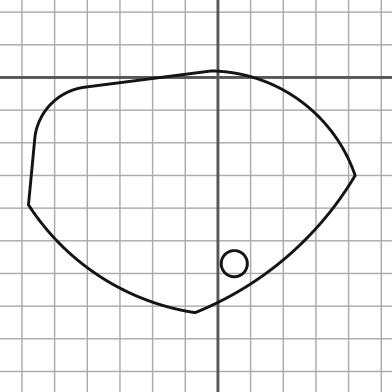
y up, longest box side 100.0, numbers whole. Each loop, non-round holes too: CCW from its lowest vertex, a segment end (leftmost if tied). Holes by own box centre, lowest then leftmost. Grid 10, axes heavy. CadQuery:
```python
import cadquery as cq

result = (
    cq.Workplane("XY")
    .moveTo(-7.0, -72.0)
    .threePointArc((21.0, -55.0), (42.0, -30.0))
    .threePointArc((25.0, -7.0), (-2.0, 2.0))
    .lineTo(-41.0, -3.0)
    .threePointArc((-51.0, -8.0), (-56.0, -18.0))
    .lineTo(-58.0, -39.0)
    .threePointArc((-36.0, -61.0), (-7.0, -72.0))
    .close()
    .moveTo(5.0, -57.0)
    .circle(4.0)
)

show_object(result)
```